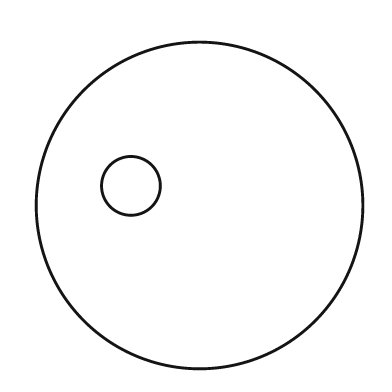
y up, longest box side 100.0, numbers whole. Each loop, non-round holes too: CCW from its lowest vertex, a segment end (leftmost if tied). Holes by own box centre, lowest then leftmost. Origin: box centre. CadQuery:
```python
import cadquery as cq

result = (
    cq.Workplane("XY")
    .moveTo(0.0, 0.0)
    .circle(50.0)
    .moveTo(-21.0, 6.0)
    .circle(9.0)
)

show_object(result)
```